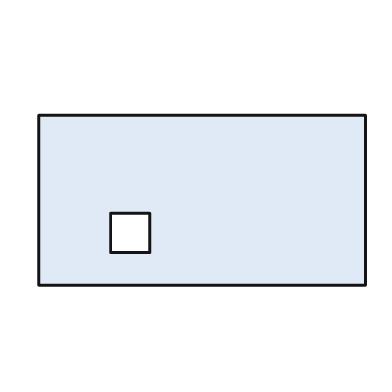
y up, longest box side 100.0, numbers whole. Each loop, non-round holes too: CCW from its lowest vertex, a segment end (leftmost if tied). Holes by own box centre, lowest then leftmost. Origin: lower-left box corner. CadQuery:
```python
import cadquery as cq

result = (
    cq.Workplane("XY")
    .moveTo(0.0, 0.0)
    .lineTo(100.0, 0.0)
    .lineTo(100.0, 52.0)
    .lineTo(0.0, 52.0)
    .close()
    .moveTo(22.0, 10.0)
    .lineTo(34.0, 10.0)
    .lineTo(34.0, 22.0)
    .lineTo(22.0, 22.0)
    .close()
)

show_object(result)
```